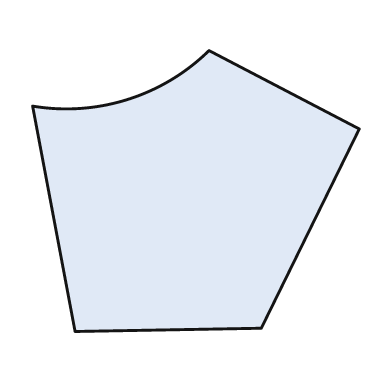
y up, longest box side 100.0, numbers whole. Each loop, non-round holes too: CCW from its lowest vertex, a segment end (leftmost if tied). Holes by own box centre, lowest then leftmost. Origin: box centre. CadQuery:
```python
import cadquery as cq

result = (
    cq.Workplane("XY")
    .moveTo(-37.0, -43.0)
    .lineTo(20.0, -42.0)
    .lineTo(50.0, 19.0)
    .lineTo(4.0, 43.0)
    .threePointArc((-21.0, 28.0), (-50.0, 26.0))
    .close()
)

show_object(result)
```